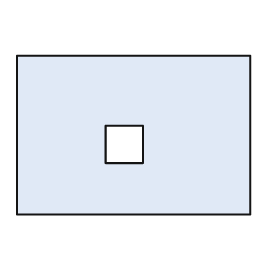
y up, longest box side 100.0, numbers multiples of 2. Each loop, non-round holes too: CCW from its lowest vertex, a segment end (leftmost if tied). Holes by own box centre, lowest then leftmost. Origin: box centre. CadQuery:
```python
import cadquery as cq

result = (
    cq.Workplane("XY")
    .moveTo(-50.0, -34.0)
    .lineTo(50.0, -34.0)
    .lineTo(50.0, 34.0)
    .lineTo(-50.0, 34.0)
    .close()
    .moveTo(-12.0, -12.0)
    .lineTo(4.0, -12.0)
    .lineTo(4.0, 4.0)
    .lineTo(-12.0, 4.0)
    .close()
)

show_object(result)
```